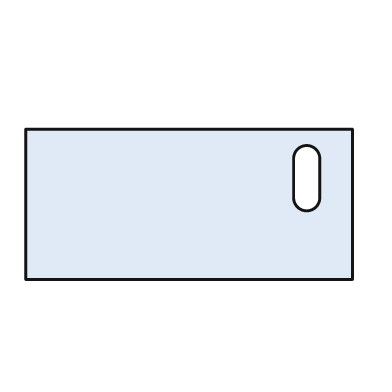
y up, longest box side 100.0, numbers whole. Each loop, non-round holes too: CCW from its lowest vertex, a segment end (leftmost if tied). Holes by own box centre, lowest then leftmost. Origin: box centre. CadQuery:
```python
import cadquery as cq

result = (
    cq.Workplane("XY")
    .moveTo(-50.0, -23.0)
    .lineTo(50.0, -23.0)
    .lineTo(50.0, 23.0)
    .lineTo(-50.0, 23.0)
    .close()
    .moveTo(32.0, 2.0)
    .threePointArc((36.0, -2.0), (40.0, 2.0))
    .lineTo(40.0, 14.0)
    .threePointArc((36.0, 18.0), (32.0, 14.0))
    .close()
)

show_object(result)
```